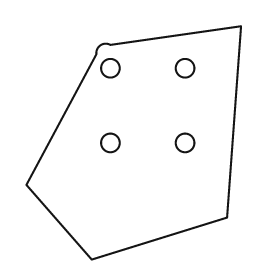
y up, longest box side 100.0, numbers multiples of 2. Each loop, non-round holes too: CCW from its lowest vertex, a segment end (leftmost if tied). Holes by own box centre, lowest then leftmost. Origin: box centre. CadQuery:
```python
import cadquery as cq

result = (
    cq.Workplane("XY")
    .moveTo(-18.0, -50.0)
    .lineTo(40.0, -32.0)
    .lineTo(46.0, 50.0)
    .lineTo(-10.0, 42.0)
    .threePointArc((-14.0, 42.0), (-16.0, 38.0))
    .lineTo(-46.0, -18.0)
    .close()
    .moveTo(-10.0, 0.0)
    .circle(4.0)
    .moveTo(22.0, 0.0)
    .circle(4.0)
    .moveTo(-10.0, 32.0)
    .circle(4.0)
    .moveTo(22.0, 32.0)
    .circle(4.0)
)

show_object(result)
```